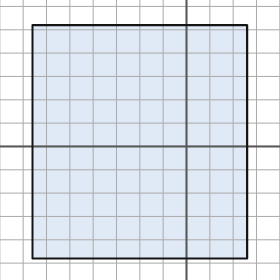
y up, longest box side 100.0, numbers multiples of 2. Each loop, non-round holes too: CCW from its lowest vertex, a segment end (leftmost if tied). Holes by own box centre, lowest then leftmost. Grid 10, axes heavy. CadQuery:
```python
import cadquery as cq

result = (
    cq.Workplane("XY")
    .moveTo(-66.0, -48.0)
    .lineTo(26.0, -48.0)
    .lineTo(26.0, 52.0)
    .lineTo(-66.0, 52.0)
    .close()
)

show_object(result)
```